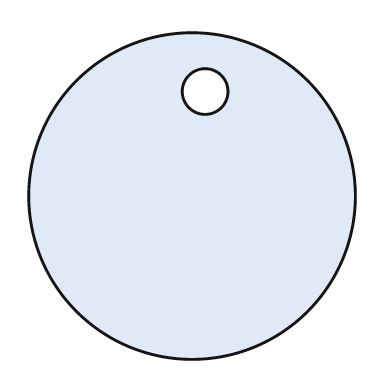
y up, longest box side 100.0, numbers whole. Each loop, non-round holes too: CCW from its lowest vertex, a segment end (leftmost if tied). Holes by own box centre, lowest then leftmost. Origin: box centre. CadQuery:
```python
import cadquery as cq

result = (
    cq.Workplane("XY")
    .moveTo(0.0, 0.0)
    .circle(50.0)
    .moveTo(4.0, 32.0)
    .circle(7.0)
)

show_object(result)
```